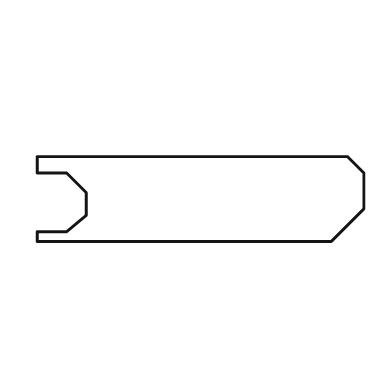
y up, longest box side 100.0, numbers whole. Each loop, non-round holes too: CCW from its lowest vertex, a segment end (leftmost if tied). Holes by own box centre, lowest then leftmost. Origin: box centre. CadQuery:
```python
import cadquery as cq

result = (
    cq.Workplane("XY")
    .moveTo(-50.0, -13.0)
    .lineTo(40.0, -13.0)
    .lineTo(50.0, -3.0)
    .lineTo(50.0, 8.0)
    .lineTo(45.0, 13.0)
    .lineTo(-50.0, 13.0)
    .lineTo(-50.0, 8.0)
    .lineTo(-41.0, 8.0)
    .lineTo(-35.0, 2.0)
    .lineTo(-35.0, -5.0)
    .lineTo(-41.0, -10.0)
    .lineTo(-50.0, -10.0)
    .close()
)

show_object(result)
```